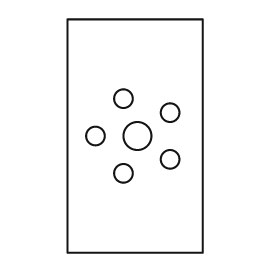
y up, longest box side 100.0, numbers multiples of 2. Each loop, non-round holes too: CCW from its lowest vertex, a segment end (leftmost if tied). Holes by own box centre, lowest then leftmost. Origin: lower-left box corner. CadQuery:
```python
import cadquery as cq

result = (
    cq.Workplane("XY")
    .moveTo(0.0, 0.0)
    .lineTo(58.0, 0.0)
    .lineTo(58.0, 100.0)
    .lineTo(0.0, 100.0)
    .close()
    .moveTo(24.0, 34.0)
    .circle(4.0)
    .moveTo(44.0, 40.0)
    .circle(4.0)
    .moveTo(12.0, 50.0)
    .circle(4.0)
    .moveTo(30.0, 50.0)
    .circle(6.0)
    .moveTo(44.0, 60.0)
    .circle(4.0)
    .moveTo(24.0, 66.0)
    .circle(4.0)
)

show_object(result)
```